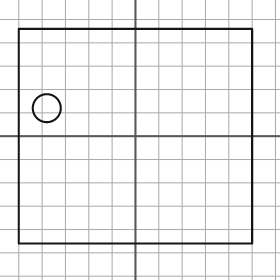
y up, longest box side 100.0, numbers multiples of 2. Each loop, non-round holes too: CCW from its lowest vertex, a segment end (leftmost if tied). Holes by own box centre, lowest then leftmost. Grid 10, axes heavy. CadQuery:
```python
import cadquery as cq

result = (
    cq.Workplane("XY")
    .moveTo(-50.0, -46.0)
    .lineTo(50.0, -46.0)
    .lineTo(50.0, 46.0)
    .lineTo(-50.0, 46.0)
    .close()
    .moveTo(-38.0, 12.0)
    .circle(6.0)
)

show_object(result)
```